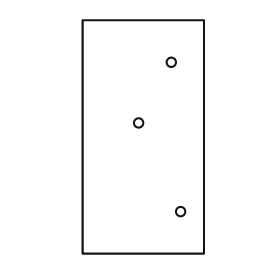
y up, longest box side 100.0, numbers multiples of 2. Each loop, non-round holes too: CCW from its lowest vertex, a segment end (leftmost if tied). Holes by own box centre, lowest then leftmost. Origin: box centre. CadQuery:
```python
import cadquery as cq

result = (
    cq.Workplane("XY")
    .moveTo(-26.0, -50.0)
    .lineTo(26.0, -50.0)
    .lineTo(26.0, 50.0)
    .lineTo(-26.0, 50.0)
    .close()
    .moveTo(16.0, -32.0)
    .circle(2.0)
    .moveTo(-2.0, 6.0)
    .circle(2.0)
    .moveTo(12.0, 32.0)
    .circle(2.0)
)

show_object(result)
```